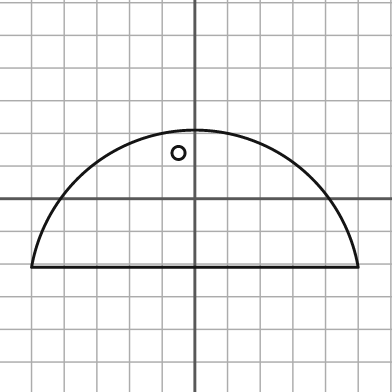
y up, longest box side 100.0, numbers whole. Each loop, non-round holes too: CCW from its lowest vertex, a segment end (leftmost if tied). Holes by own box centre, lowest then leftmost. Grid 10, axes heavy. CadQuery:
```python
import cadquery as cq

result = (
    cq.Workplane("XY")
    .moveTo(-50.0, -21.0)
    .lineTo(50.0, -21.0)
    .threePointArc((0.0, 21.0), (-50.0, -21.0))
    .close()
    .moveTo(-5.0, 14.0)
    .circle(2.0)
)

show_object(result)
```